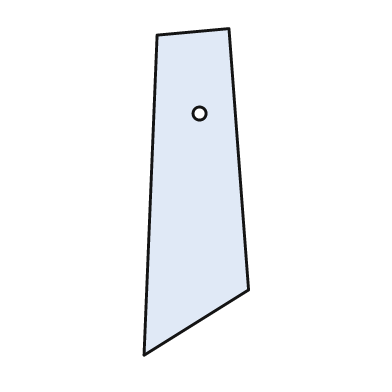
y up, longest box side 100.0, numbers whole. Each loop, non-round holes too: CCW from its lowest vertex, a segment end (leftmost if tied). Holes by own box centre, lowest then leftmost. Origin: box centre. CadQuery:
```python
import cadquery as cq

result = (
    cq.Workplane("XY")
    .moveTo(-16.0, -50.0)
    .lineTo(16.0, -30.0)
    .lineTo(10.0, 50.0)
    .lineTo(-12.0, 48.0)
    .close()
    .moveTo(1.0, 24.0)
    .circle(2.0)
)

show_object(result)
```